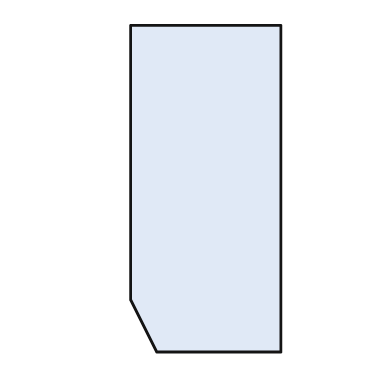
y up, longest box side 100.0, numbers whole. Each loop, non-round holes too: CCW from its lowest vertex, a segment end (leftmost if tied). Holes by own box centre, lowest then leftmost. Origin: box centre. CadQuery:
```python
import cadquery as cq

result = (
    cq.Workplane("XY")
    .moveTo(-15.0, -50.0)
    .lineTo(23.0, -50.0)
    .lineTo(23.0, 50.0)
    .lineTo(-23.0, 50.0)
    .lineTo(-23.0, -34.0)
    .close()
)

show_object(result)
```